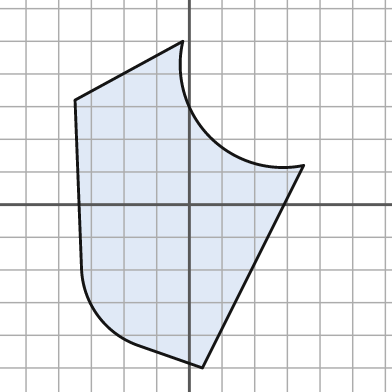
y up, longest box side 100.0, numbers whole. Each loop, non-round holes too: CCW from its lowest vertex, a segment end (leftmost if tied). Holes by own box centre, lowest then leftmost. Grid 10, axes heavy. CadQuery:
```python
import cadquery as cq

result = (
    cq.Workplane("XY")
    .moveTo(4.0, -50.0)
    .lineTo(35.0, 12.0)
    .threePointArc((6.0, 21.0), (-2.0, 50.0))
    .lineTo(-35.0, 32.0)
    .lineTo(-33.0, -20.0)
    .threePointArc((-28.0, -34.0), (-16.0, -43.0))
    .close()
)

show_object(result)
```